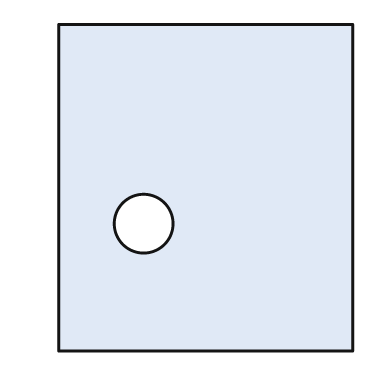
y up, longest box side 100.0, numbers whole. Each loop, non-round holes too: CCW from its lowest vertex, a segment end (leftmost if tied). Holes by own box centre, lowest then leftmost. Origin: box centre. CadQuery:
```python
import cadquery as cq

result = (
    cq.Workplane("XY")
    .moveTo(-45.0, -50.0)
    .lineTo(45.0, -50.0)
    .lineTo(45.0, 50.0)
    .lineTo(-45.0, 50.0)
    .close()
    .moveTo(-19.0, -11.0)
    .circle(9.0)
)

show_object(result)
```